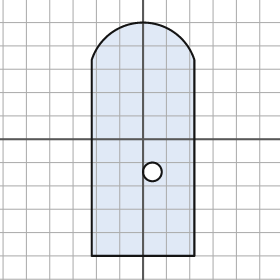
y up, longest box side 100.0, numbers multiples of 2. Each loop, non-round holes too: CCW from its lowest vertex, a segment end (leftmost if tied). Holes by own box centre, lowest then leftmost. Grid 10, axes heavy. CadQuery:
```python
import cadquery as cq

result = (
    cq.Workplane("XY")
    .moveTo(-22.0, -50.0)
    .lineTo(22.0, -50.0)
    .lineTo(22.0, 34.0)
    .threePointArc((0.0, 50.0), (-22.0, 34.0))
    .close()
    .moveTo(4.0, -14.0)
    .circle(4.0)
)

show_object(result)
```